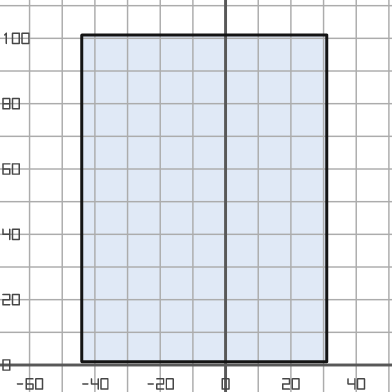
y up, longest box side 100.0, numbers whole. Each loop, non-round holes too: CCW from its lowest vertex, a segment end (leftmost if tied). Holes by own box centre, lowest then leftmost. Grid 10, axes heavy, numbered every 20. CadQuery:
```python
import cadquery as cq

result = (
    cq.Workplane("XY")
    .moveTo(-44.0, 1.0)
    .lineTo(31.0, 1.0)
    .lineTo(31.0, 101.0)
    .lineTo(-44.0, 101.0)
    .close()
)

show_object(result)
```